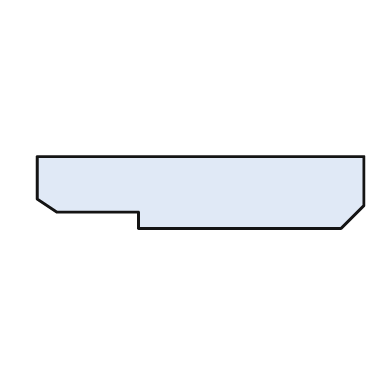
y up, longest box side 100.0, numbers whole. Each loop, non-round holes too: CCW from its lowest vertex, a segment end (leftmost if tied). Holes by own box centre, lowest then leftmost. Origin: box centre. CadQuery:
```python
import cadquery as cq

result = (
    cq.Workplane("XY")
    .moveTo(-19.0, -11.0)
    .lineTo(43.0, -11.0)
    .lineTo(50.0, -4.0)
    .lineTo(50.0, 11.0)
    .lineTo(-50.0, 11.0)
    .lineTo(-50.0, -2.0)
    .lineTo(-44.0, -6.0)
    .lineTo(-19.0, -6.0)
    .close()
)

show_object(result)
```